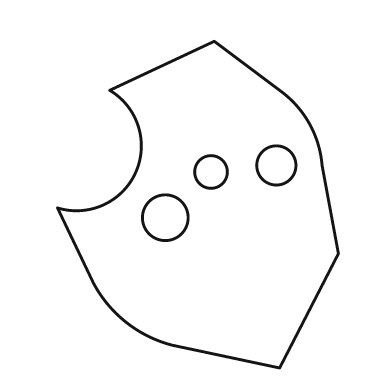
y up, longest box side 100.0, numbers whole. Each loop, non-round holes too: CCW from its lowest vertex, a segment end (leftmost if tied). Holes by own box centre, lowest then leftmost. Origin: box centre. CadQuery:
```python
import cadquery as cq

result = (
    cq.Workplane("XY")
    .moveTo(25.0, -50.0)
    .lineTo(43.0, -15.0)
    .lineTo(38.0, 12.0)
    .threePointArc((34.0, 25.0), (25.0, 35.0))
    .lineTo(5.0, 50.0)
    .lineTo(-27.0, 35.0)
    .threePointArc((-19.0, 10.0), (-43.0, -1.0))
    .lineTo(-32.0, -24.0)
    .threePointArc((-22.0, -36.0), (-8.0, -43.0))
    .close()
    .moveTo(-10.0, -4.0)
    .circle(7.0)
    .moveTo(4.0, 10.0)
    .circle(5.0)
    .moveTo(24.0, 12.0)
    .circle(6.0)
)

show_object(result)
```